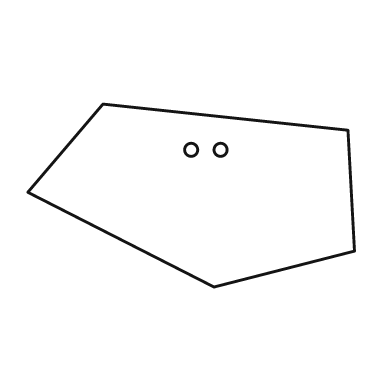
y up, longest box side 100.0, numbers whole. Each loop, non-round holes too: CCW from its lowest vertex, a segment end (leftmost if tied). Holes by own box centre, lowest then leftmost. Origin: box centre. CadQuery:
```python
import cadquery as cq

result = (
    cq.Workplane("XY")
    .moveTo(7.0, -28.0)
    .lineTo(50.0, -17.0)
    .lineTo(48.0, 20.0)
    .lineTo(-27.0, 28.0)
    .lineTo(-50.0, 1.0)
    .close()
    .moveTo(0.0, 14.0)
    .circle(2.0)
    .moveTo(9.0, 14.0)
    .circle(2.0)
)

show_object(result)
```